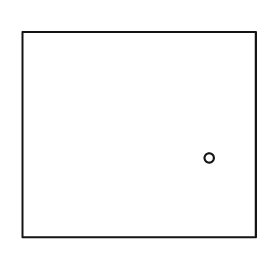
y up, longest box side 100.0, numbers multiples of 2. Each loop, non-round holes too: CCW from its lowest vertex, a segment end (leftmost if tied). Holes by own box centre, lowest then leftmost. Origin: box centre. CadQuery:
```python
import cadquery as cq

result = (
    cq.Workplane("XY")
    .moveTo(-50.0, -44.0)
    .lineTo(50.0, -44.0)
    .lineTo(50.0, 44.0)
    .lineTo(-50.0, 44.0)
    .close()
    .moveTo(30.0, -10.0)
    .circle(2.0)
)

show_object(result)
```